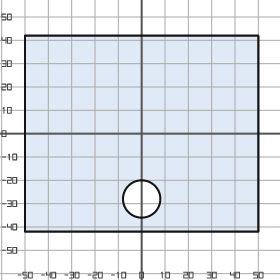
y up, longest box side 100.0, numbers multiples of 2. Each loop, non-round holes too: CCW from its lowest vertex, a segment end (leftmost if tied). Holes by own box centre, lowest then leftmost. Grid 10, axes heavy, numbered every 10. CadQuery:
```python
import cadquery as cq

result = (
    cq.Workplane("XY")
    .moveTo(-50.0, -42.0)
    .lineTo(50.0, -42.0)
    .lineTo(50.0, 42.0)
    .lineTo(-50.0, 42.0)
    .close()
    .moveTo(0.0, -28.0)
    .circle(8.0)
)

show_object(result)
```